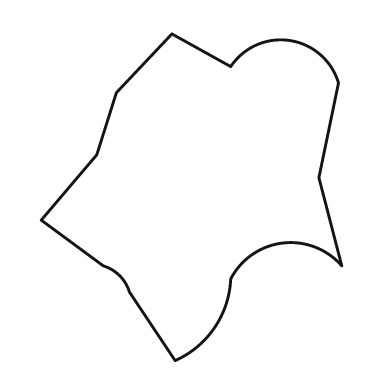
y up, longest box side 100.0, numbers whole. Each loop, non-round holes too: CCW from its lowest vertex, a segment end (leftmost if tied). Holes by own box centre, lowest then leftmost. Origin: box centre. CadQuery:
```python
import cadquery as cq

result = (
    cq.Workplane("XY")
    .moveTo(-5.0, -50.0)
    .threePointArc((7.0, -40.0), (12.0, -25.0))
    .threePointArc((28.0, -14.0), (46.0, -21.0))
    .lineTo(39.0, 6.0)
    .lineTo(45.0, 35.0)
    .threePointArc((30.0, 48.0), (12.0, 40.0))
    .lineTo(-6.0, 50.0)
    .lineTo(-23.0, 32.0)
    .lineTo(-29.0, 13.0)
    .lineTo(-46.0, -7.0)
    .lineTo(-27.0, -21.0)
    .threePointArc((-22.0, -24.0), (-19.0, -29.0))
    .close()
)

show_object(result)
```